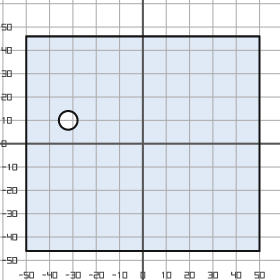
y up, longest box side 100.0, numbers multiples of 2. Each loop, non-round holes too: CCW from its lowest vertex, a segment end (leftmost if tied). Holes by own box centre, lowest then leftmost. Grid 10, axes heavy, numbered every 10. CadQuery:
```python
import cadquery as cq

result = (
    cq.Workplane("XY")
    .moveTo(-50.0, -46.0)
    .lineTo(50.0, -46.0)
    .lineTo(50.0, 46.0)
    .lineTo(-50.0, 46.0)
    .close()
    .moveTo(-32.0, 10.0)
    .circle(4.0)
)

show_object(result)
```